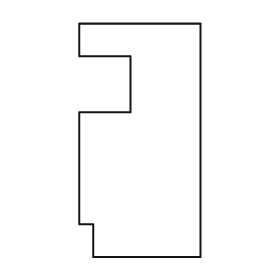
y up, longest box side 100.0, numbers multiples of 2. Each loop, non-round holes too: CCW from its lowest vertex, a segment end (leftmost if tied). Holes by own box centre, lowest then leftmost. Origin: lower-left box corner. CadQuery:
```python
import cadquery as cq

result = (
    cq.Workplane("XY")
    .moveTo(6.0, 0.0)
    .lineTo(52.0, 0.0)
    .lineTo(52.0, 100.0)
    .lineTo(0.0, 100.0)
    .lineTo(0.0, 86.0)
    .lineTo(22.0, 86.0)
    .lineTo(22.0, 62.0)
    .lineTo(0.0, 62.0)
    .lineTo(0.0, 14.0)
    .lineTo(6.0, 14.0)
    .close()
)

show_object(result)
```